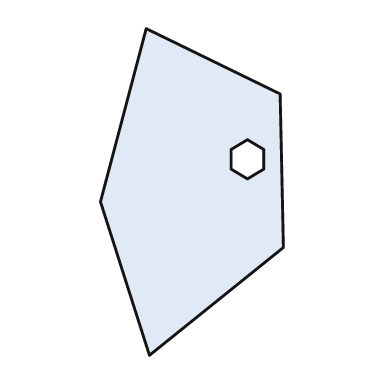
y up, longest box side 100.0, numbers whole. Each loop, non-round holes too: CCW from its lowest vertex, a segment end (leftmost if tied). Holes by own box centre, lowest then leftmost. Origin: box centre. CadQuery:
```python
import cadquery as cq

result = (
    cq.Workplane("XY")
    .moveTo(-13.0, -50.0)
    .lineTo(28.0, -17.0)
    .lineTo(27.0, 30.0)
    .lineTo(-14.0, 50.0)
    .lineTo(-28.0, -3.0)
    .close()
    .moveTo(17.0, 4.0)
    .lineTo(22.0, 7.0)
    .lineTo(22.0, 13.0)
    .lineTo(17.0, 16.0)
    .lineTo(12.0, 13.0)
    .lineTo(12.0, 7.0)
    .close()
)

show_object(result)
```